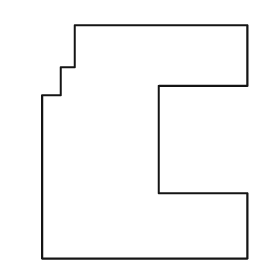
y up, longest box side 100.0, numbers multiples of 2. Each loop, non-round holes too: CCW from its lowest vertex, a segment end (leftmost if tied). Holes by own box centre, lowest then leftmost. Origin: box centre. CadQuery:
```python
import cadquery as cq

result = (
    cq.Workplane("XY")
    .moveTo(-44.0, -50.0)
    .lineTo(44.0, -50.0)
    .lineTo(44.0, -22.0)
    .lineTo(6.0, -22.0)
    .lineTo(6.0, 24.0)
    .lineTo(44.0, 24.0)
    .lineTo(44.0, 50.0)
    .lineTo(-30.0, 50.0)
    .lineTo(-30.0, 32.0)
    .lineTo(-36.0, 32.0)
    .lineTo(-36.0, 20.0)
    .lineTo(-44.0, 20.0)
    .close()
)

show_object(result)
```